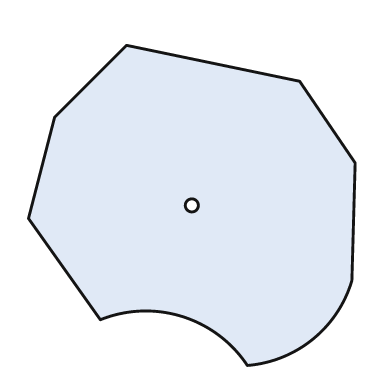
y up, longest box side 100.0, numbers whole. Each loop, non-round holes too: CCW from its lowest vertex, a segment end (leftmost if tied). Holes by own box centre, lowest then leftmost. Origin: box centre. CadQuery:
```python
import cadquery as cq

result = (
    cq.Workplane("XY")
    .moveTo(17.0, -49.0)
    .threePointArc((37.0, -41.0), (49.0, -23.0))
    .lineTo(50.0, 13.0)
    .lineTo(33.0, 38.0)
    .lineTo(-20.0, 49.0)
    .lineTo(-42.0, 27.0)
    .lineTo(-50.0, -4.0)
    .lineTo(-28.0, -35.0)
    .threePointArc((-3.0, -34.0), (17.0, -49.0))
    .close()
    .moveTo(0.0, 0.0)
    .circle(2.0)
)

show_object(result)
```